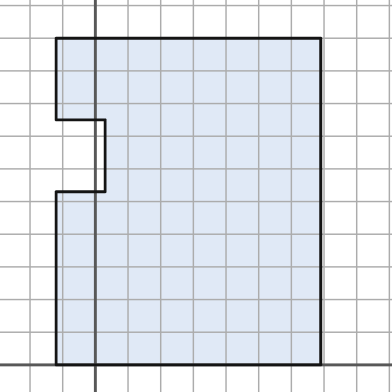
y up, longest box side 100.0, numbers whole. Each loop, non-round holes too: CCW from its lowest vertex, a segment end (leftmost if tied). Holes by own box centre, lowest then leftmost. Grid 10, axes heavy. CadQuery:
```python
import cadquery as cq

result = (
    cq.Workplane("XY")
    .moveTo(-12.0, 0.0)
    .lineTo(69.0, 0.0)
    .lineTo(69.0, 100.0)
    .lineTo(-12.0, 100.0)
    .lineTo(-12.0, 75.0)
    .lineTo(3.0, 75.0)
    .lineTo(3.0, 53.0)
    .lineTo(-12.0, 53.0)
    .close()
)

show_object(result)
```